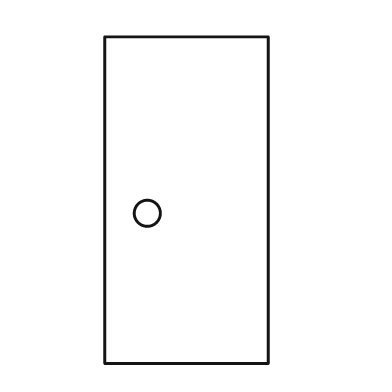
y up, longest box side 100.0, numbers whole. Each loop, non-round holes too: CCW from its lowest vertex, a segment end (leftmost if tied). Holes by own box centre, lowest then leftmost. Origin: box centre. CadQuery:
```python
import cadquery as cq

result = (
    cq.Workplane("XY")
    .moveTo(-25.0, -50.0)
    .lineTo(25.0, -50.0)
    .lineTo(25.0, 50.0)
    .lineTo(-25.0, 50.0)
    .close()
    .moveTo(-12.0, -4.0)
    .circle(4.0)
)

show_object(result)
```